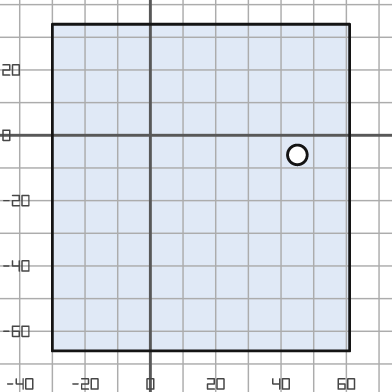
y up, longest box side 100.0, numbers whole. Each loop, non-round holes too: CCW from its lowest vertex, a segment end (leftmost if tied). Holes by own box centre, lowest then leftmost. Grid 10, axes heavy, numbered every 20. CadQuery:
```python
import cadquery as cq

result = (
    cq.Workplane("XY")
    .moveTo(-30.0, -66.0)
    .lineTo(61.0, -66.0)
    .lineTo(61.0, 34.0)
    .lineTo(-30.0, 34.0)
    .close()
    .moveTo(45.0, -6.0)
    .circle(3.0)
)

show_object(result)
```